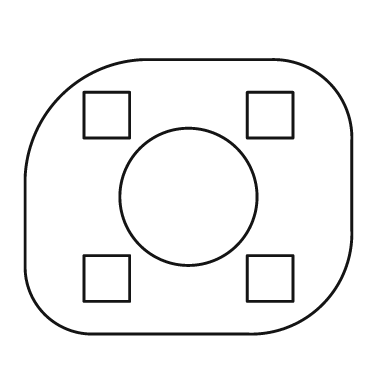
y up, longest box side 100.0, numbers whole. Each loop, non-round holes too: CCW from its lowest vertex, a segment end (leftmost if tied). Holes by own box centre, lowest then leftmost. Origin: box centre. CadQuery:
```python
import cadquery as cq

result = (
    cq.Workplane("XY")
    .moveTo(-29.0, -42.0)
    .lineTo(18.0, -42.0)
    .threePointArc((41.0, -33.0), (50.0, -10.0))
    .lineTo(50.0, 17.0)
    .threePointArc((43.0, 35.0), (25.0, 42.0))
    .lineTo(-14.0, 42.0)
    .threePointArc((-39.0, 31.0), (-50.0, 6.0))
    .lineTo(-50.0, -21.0)
    .threePointArc((-44.0, -36.0), (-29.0, -42.0))
    .close()
    .moveTo(-32.0, -32.0)
    .lineTo(-18.0, -32.0)
    .lineTo(-18.0, -18.0)
    .lineTo(-32.0, -18.0)
    .close()
    .moveTo(18.0, -32.0)
    .lineTo(32.0, -32.0)
    .lineTo(32.0, -18.0)
    .lineTo(18.0, -18.0)
    .close()
    .moveTo(0.0, 0.0)
    .circle(21.0)
    .moveTo(-32.0, 18.0)
    .lineTo(-18.0, 18.0)
    .lineTo(-18.0, 32.0)
    .lineTo(-32.0, 32.0)
    .close()
    .moveTo(18.0, 18.0)
    .lineTo(32.0, 18.0)
    .lineTo(32.0, 32.0)
    .lineTo(18.0, 32.0)
    .close()
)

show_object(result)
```